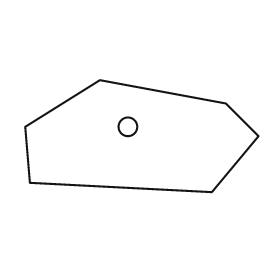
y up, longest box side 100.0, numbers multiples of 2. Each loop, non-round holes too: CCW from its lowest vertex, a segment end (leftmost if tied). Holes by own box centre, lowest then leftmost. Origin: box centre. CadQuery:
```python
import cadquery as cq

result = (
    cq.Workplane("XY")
    .moveTo(30.0, -24.0)
    .lineTo(50.0, 0.0)
    .lineTo(36.0, 14.0)
    .lineTo(-18.0, 24.0)
    .lineTo(-50.0, 4.0)
    .lineTo(-48.0, -20.0)
    .close()
    .moveTo(-6.0, 4.0)
    .circle(4.0)
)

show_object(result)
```